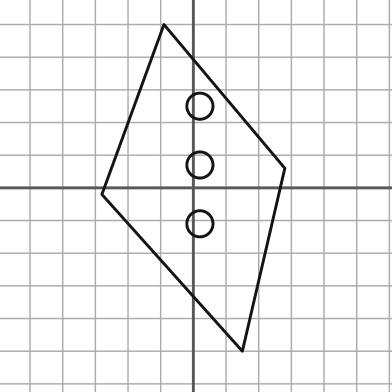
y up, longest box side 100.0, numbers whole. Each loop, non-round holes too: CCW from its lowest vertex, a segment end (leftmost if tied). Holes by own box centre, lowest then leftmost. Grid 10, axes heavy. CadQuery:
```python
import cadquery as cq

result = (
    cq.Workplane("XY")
    .moveTo(15.0, -50.0)
    .lineTo(28.0, 6.0)
    .lineTo(-9.0, 50.0)
    .lineTo(-28.0, -2.0)
    .close()
    .moveTo(2.0, -11.0)
    .circle(4.0)
    .moveTo(2.0, 7.0)
    .circle(4.0)
    .moveTo(2.0, 25.0)
    .circle(4.0)
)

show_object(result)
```